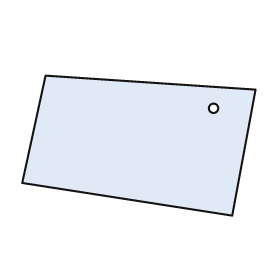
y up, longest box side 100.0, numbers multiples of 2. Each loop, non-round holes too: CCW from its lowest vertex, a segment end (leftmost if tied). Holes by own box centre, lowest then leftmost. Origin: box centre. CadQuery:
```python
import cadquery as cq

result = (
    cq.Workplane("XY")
    .moveTo(40.0, -30.0)
    .lineTo(50.0, 24.0)
    .lineTo(-40.0, 30.0)
    .lineTo(-50.0, -16.0)
    .close()
    .moveTo(32.0, 16.0)
    .circle(2.0)
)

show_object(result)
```